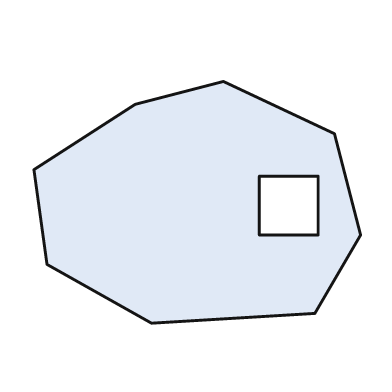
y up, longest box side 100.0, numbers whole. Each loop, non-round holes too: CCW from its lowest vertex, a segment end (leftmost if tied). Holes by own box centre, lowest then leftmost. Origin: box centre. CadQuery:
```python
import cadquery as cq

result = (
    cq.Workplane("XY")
    .moveTo(-14.0, -37.0)
    .lineTo(36.0, -34.0)
    .lineTo(50.0, -10.0)
    .lineTo(42.0, 21.0)
    .lineTo(8.0, 37.0)
    .lineTo(-19.0, 30.0)
    .lineTo(-50.0, 10.0)
    .lineTo(-46.0, -19.0)
    .close()
    .moveTo(19.0, -10.0)
    .lineTo(37.0, -10.0)
    .lineTo(37.0, 8.0)
    .lineTo(19.0, 8.0)
    .close()
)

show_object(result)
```